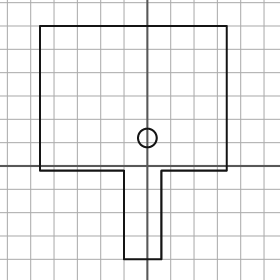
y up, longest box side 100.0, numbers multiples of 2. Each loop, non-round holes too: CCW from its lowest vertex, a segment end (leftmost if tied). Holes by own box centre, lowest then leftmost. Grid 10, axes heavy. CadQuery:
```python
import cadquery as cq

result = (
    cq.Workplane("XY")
    .moveTo(-10.0, -40.0)
    .lineTo(6.0, -40.0)
    .lineTo(6.0, -2.0)
    .lineTo(34.0, -2.0)
    .lineTo(34.0, 60.0)
    .lineTo(-46.0, 60.0)
    .lineTo(-46.0, -2.0)
    .lineTo(-10.0, -2.0)
    .close()
    .moveTo(0.0, 12.0)
    .circle(4.0)
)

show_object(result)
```